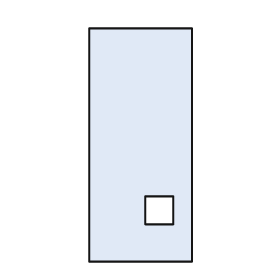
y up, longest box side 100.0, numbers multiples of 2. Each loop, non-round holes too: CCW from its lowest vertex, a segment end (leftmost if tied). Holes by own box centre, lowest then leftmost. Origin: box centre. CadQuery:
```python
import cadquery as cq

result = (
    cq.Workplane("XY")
    .moveTo(-22.0, -50.0)
    .lineTo(22.0, -50.0)
    .lineTo(22.0, 50.0)
    .lineTo(-22.0, 50.0)
    .close()
    .moveTo(2.0, -34.0)
    .lineTo(14.0, -34.0)
    .lineTo(14.0, -22.0)
    .lineTo(2.0, -22.0)
    .close()
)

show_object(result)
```